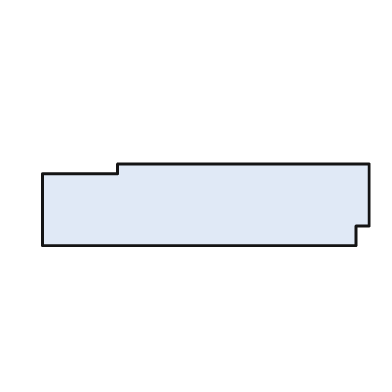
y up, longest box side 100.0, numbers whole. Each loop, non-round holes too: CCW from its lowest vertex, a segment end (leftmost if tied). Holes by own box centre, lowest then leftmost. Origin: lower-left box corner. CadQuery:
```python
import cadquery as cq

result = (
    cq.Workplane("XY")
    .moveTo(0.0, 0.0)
    .lineTo(96.0, 0.0)
    .lineTo(96.0, 6.0)
    .lineTo(100.0, 6.0)
    .lineTo(100.0, 25.0)
    .lineTo(23.0, 25.0)
    .lineTo(23.0, 22.0)
    .lineTo(0.0, 22.0)
    .close()
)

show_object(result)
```